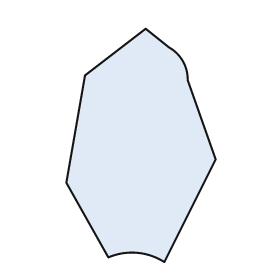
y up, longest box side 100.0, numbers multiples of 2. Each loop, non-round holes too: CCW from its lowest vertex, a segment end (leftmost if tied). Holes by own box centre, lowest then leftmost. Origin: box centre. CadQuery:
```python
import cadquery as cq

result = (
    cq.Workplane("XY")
    .moveTo(10.0, -50.0)
    .lineTo(32.0, -6.0)
    .lineTo(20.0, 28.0)
    .threePointArc((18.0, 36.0), (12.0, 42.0))
    .lineTo(2.0, 50.0)
    .lineTo(-24.0, 30.0)
    .lineTo(-32.0, -16.0)
    .lineTo(-14.0, -48.0)
    .threePointArc((-2.0, -46.0), (10.0, -50.0))
    .close()
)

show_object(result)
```